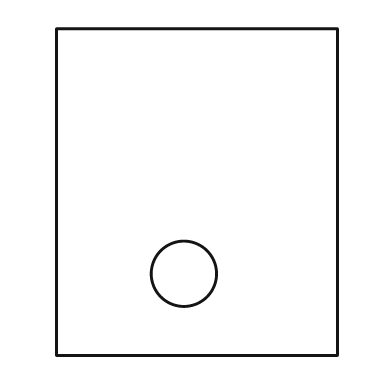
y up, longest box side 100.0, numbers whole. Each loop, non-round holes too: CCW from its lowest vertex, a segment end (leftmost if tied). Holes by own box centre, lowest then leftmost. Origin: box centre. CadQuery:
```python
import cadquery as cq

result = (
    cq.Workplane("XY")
    .moveTo(-43.0, -50.0)
    .lineTo(43.0, -50.0)
    .lineTo(43.0, 50.0)
    .lineTo(-43.0, 50.0)
    .close()
    .moveTo(-4.0, -25.0)
    .circle(10.0)
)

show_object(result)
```